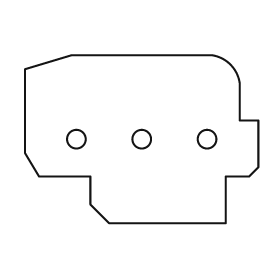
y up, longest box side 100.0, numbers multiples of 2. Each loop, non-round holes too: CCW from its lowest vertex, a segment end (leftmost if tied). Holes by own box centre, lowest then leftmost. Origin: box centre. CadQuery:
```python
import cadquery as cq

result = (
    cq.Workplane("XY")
    .moveTo(-14.0, -36.0)
    .lineTo(36.0, -36.0)
    .lineTo(36.0, -16.0)
    .lineTo(46.0, -16.0)
    .lineTo(50.0, -12.0)
    .lineTo(50.0, 8.0)
    .lineTo(42.0, 8.0)
    .lineTo(42.0, 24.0)
    .threePointArc((38.0, 32.0), (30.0, 36.0))
    .lineTo(-30.0, 36.0)
    .lineTo(-50.0, 30.0)
    .lineTo(-50.0, -6.0)
    .lineTo(-44.0, -16.0)
    .lineTo(-22.0, -16.0)
    .lineTo(-22.0, -28.0)
    .close()
    .moveTo(-28.0, 0.0)
    .circle(4.0)
    .moveTo(0.0, 0.0)
    .circle(4.0)
    .moveTo(28.0, 0.0)
    .circle(4.0)
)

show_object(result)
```